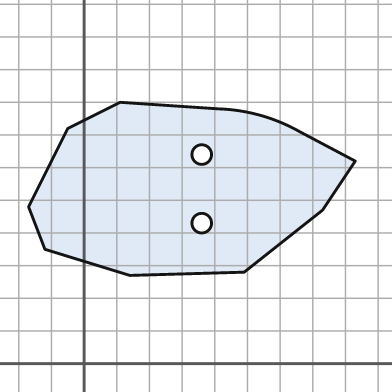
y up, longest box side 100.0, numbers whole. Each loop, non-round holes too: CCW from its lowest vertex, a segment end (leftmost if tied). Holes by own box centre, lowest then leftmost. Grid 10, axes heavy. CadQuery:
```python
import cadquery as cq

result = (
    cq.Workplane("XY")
    .moveTo(14.0, 27.0)
    .lineTo(49.0, 28.0)
    .lineTo(73.0, 47.0)
    .lineTo(83.0, 62.0)
    .lineTo(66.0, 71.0)
    .threePointArc((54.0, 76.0), (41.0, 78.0))
    .lineTo(11.0, 80.0)
    .lineTo(-5.0, 72.0)
    .lineTo(-17.0, 48.0)
    .lineTo(-12.0, 35.0)
    .close()
    .moveTo(36.0, 43.0)
    .circle(3.0)
    .moveTo(36.0, 64.0)
    .circle(3.0)
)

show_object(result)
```